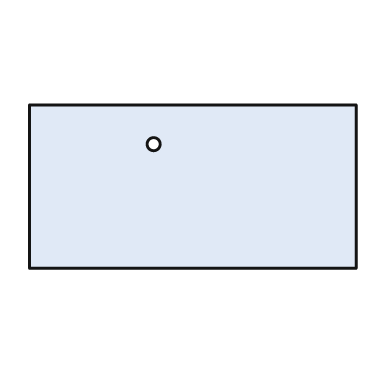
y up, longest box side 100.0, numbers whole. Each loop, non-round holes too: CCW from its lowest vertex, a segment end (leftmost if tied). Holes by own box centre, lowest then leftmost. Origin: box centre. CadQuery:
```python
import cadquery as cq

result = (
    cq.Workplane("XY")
    .moveTo(-50.0, -25.0)
    .lineTo(50.0, -25.0)
    .lineTo(50.0, 25.0)
    .lineTo(-50.0, 25.0)
    .close()
    .moveTo(-12.0, 13.0)
    .circle(2.0)
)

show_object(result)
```